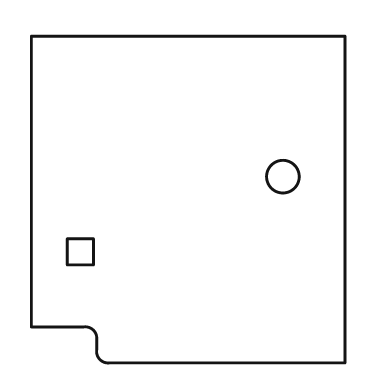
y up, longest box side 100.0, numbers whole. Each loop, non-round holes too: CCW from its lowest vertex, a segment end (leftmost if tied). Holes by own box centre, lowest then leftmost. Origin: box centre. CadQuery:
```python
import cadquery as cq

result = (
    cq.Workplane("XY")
    .moveTo(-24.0, -50.0)
    .lineTo(48.0, -50.0)
    .lineTo(48.0, 50.0)
    .lineTo(-48.0, 50.0)
    .lineTo(-48.0, -39.0)
    .lineTo(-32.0, -39.0)
    .threePointArc((-29.0, -40.0), (-28.0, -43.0))
    .lineTo(-28.0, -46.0)
    .threePointArc((-27.0, -49.0), (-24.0, -50.0))
    .close()
    .moveTo(-37.0, -20.0)
    .lineTo(-29.0, -20.0)
    .lineTo(-29.0, -12.0)
    .lineTo(-37.0, -12.0)
    .close()
    .moveTo(29.0, 7.0)
    .circle(5.0)
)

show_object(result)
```